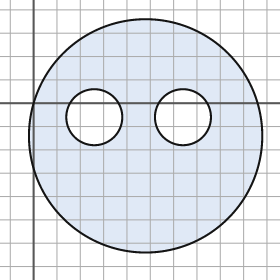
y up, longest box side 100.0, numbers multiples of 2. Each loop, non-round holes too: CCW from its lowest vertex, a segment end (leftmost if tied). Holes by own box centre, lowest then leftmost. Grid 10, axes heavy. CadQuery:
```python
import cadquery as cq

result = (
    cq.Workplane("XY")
    .moveTo(48.0, -14.0)
    .circle(50.0)
    .moveTo(26.0, -6.0)
    .circle(12.0)
    .moveTo(64.0, -6.0)
    .circle(12.0)
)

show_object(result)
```